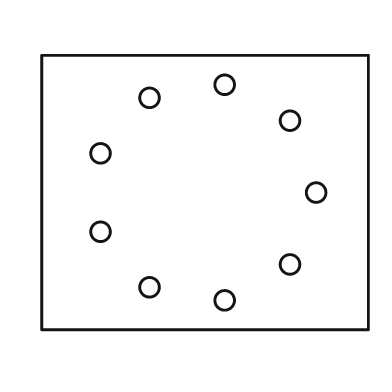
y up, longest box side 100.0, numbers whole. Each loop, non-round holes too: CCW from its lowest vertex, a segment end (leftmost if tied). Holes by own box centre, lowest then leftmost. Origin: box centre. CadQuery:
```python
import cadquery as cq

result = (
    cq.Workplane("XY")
    .moveTo(-50.0, -42.0)
    .lineTo(50.0, -42.0)
    .lineTo(50.0, 42.0)
    .lineTo(-50.0, 42.0)
    .close()
    .moveTo(6.0, -33.0)
    .circle(3.0)
    .moveTo(-17.0, -29.0)
    .circle(3.0)
    .moveTo(26.0, -22.0)
    .circle(3.0)
    .moveTo(-32.0, -12.0)
    .circle(3.0)
    .moveTo(34.0, 0.0)
    .circle(3.0)
    .moveTo(-32.0, 12.0)
    .circle(3.0)
    .moveTo(26.0, 22.0)
    .circle(3.0)
    .moveTo(-17.0, 29.0)
    .circle(3.0)
    .moveTo(6.0, 33.0)
    .circle(3.0)
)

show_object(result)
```